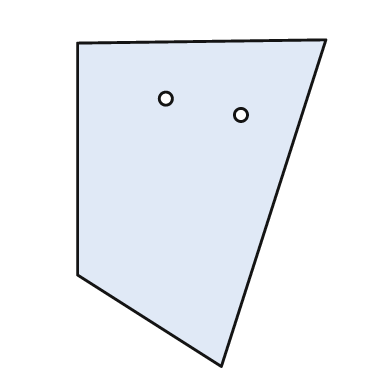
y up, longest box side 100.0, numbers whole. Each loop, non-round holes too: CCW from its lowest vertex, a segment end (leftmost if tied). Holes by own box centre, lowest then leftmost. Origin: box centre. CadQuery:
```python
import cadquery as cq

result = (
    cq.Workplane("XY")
    .moveTo(6.0, -50.0)
    .lineTo(38.0, 50.0)
    .lineTo(-38.0, 49.0)
    .lineTo(-38.0, -22.0)
    .close()
    .moveTo(12.0, 27.0)
    .circle(2.0)
    .moveTo(-11.0, 32.0)
    .circle(2.0)
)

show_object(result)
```